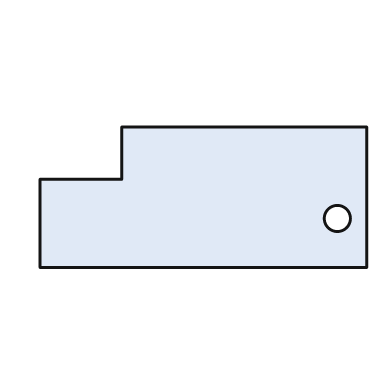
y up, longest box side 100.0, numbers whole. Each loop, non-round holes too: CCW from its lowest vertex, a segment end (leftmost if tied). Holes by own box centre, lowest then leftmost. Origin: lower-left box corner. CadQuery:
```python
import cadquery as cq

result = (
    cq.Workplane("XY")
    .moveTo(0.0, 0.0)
    .lineTo(100.0, 0.0)
    .lineTo(100.0, 43.0)
    .lineTo(25.0, 43.0)
    .lineTo(25.0, 27.0)
    .lineTo(0.0, 27.0)
    .close()
    .moveTo(91.0, 15.0)
    .circle(4.0)
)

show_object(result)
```